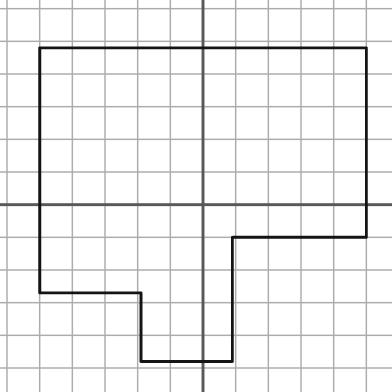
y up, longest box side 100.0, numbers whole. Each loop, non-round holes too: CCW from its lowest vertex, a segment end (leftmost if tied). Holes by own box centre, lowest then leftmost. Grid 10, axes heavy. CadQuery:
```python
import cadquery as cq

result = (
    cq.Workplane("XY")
    .moveTo(-19.0, -48.0)
    .lineTo(9.0, -48.0)
    .lineTo(9.0, -10.0)
    .lineTo(50.0, -10.0)
    .lineTo(50.0, 48.0)
    .lineTo(-50.0, 48.0)
    .lineTo(-50.0, -27.0)
    .lineTo(-19.0, -27.0)
    .close()
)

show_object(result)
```